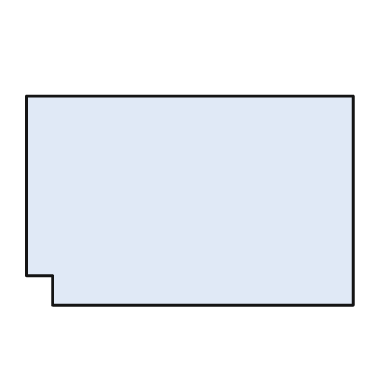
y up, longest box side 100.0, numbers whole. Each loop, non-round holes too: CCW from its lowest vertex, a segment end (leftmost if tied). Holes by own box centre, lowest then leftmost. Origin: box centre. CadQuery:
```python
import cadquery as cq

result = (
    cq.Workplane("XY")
    .moveTo(-42.0, -32.0)
    .lineTo(50.0, -32.0)
    .lineTo(50.0, 32.0)
    .lineTo(-50.0, 32.0)
    .lineTo(-50.0, -23.0)
    .lineTo(-42.0, -23.0)
    .close()
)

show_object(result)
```